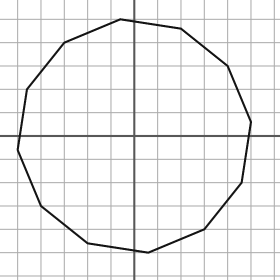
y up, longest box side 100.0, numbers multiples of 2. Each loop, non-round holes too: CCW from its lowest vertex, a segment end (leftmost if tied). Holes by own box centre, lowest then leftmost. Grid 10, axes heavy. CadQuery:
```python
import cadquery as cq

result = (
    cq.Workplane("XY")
    .moveTo(6.0, -50.0)
    .lineTo(30.0, -40.0)
    .lineTo(46.0, -20.0)
    .lineTo(50.0, 6.0)
    .lineTo(40.0, 30.0)
    .lineTo(20.0, 46.0)
    .lineTo(-6.0, 50.0)
    .lineTo(-30.0, 40.0)
    .lineTo(-46.0, 20.0)
    .lineTo(-50.0, -6.0)
    .lineTo(-40.0, -30.0)
    .lineTo(-20.0, -46.0)
    .close()
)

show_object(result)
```